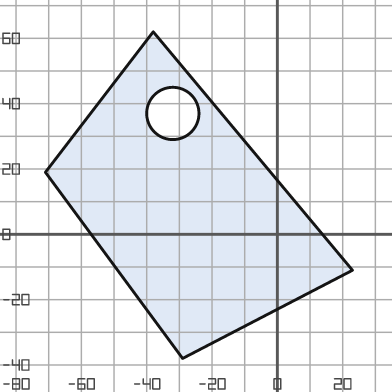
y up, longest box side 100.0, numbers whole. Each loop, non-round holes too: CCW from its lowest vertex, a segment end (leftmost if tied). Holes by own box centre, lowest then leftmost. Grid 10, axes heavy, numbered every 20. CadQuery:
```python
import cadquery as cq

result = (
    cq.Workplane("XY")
    .moveTo(-29.0, -38.0)
    .lineTo(23.0, -11.0)
    .lineTo(-38.0, 62.0)
    .lineTo(-71.0, 19.0)
    .close()
    .moveTo(-32.0, 37.0)
    .circle(8.0)
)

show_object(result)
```